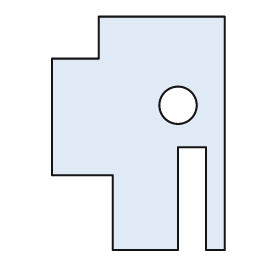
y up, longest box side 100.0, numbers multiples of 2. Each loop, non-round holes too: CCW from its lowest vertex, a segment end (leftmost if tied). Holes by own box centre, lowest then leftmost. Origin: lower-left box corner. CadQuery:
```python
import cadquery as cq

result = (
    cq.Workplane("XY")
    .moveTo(26.0, 0.0)
    .lineTo(54.0, 0.0)
    .lineTo(54.0, 44.0)
    .lineTo(66.0, 44.0)
    .lineTo(66.0, 0.0)
    .lineTo(74.0, 0.0)
    .lineTo(74.0, 100.0)
    .lineTo(20.0, 100.0)
    .lineTo(20.0, 82.0)
    .lineTo(0.0, 82.0)
    .lineTo(0.0, 32.0)
    .lineTo(26.0, 32.0)
    .close()
    .moveTo(54.0, 62.0)
    .circle(8.0)
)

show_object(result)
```